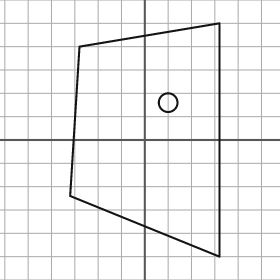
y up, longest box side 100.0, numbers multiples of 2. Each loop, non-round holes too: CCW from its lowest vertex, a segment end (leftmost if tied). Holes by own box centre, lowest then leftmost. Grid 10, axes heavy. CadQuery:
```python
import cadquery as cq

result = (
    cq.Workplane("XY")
    .moveTo(32.0, -50.0)
    .lineTo(32.0, 50.0)
    .lineTo(-28.0, 40.0)
    .lineTo(-32.0, -24.0)
    .close()
    .moveTo(10.0, 16.0)
    .circle(4.0)
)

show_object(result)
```